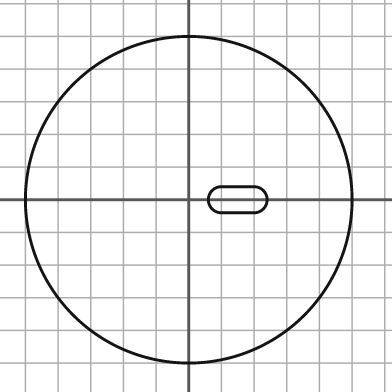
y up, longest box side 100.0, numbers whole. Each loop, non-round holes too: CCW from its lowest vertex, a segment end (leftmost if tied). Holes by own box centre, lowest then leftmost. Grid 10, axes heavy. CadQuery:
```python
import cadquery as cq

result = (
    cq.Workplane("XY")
    .moveTo(0.0, 0.0)
    .circle(50.0)
    .moveTo(10.0, -4.0)
    .lineTo(20.0, -4.0)
    .threePointArc((24.0, 0.0), (20.0, 4.0))
    .lineTo(10.0, 4.0)
    .threePointArc((6.0, 0.0), (10.0, -4.0))
    .close()
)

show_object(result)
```